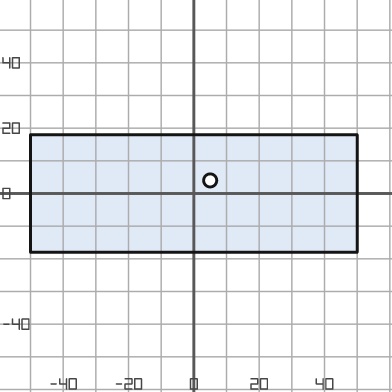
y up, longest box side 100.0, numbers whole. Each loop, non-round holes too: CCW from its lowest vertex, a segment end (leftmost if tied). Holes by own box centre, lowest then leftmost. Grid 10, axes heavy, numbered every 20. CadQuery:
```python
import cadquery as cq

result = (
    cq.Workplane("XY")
    .moveTo(-50.0, -18.0)
    .lineTo(50.0, -18.0)
    .lineTo(50.0, 18.0)
    .lineTo(-50.0, 18.0)
    .close()
    .moveTo(5.0, 4.0)
    .circle(2.0)
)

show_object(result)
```